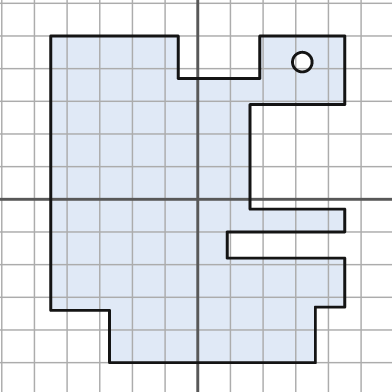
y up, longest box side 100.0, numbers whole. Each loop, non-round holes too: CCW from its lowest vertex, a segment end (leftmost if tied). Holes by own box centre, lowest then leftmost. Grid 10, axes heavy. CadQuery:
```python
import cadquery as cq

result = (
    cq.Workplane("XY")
    .moveTo(-27.0, -50.0)
    .lineTo(36.0, -50.0)
    .lineTo(36.0, -33.0)
    .lineTo(45.0, -33.0)
    .lineTo(45.0, -18.0)
    .lineTo(9.0, -18.0)
    .lineTo(9.0, -10.0)
    .lineTo(45.0, -10.0)
    .lineTo(45.0, -3.0)
    .lineTo(16.0, -3.0)
    .lineTo(16.0, 29.0)
    .lineTo(45.0, 29.0)
    .lineTo(45.0, 50.0)
    .lineTo(19.0, 50.0)
    .lineTo(19.0, 37.0)
    .lineTo(-6.0, 37.0)
    .lineTo(-6.0, 50.0)
    .lineTo(-45.0, 50.0)
    .lineTo(-45.0, -34.0)
    .lineTo(-27.0, -34.0)
    .close()
    .moveTo(32.0, 42.0)
    .circle(3.0)
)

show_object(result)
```